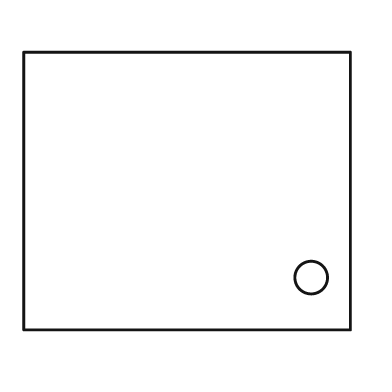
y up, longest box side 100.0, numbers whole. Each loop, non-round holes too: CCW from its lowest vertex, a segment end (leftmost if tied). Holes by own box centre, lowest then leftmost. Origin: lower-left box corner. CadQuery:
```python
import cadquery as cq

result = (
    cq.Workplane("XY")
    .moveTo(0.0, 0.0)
    .lineTo(100.0, 0.0)
    .lineTo(100.0, 85.0)
    .lineTo(0.0, 85.0)
    .close()
    .moveTo(88.0, 16.0)
    .circle(5.0)
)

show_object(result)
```